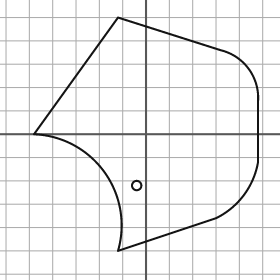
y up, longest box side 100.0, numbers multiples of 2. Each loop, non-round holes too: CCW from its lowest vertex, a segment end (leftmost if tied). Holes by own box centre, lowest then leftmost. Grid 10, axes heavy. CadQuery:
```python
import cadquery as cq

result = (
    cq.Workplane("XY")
    .moveTo(-12.0, -50.0)
    .lineTo(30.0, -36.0)
    .threePointArc((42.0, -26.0), (48.0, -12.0))
    .lineTo(48.0, 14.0)
    .threePointArc((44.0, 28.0), (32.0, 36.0))
    .lineTo(-12.0, 50.0)
    .lineTo(-48.0, 0.0)
    .threePointArc((-18.0, -16.0), (-12.0, -50.0))
    .close()
    .moveTo(-4.0, -22.0)
    .circle(2.0)
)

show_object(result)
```